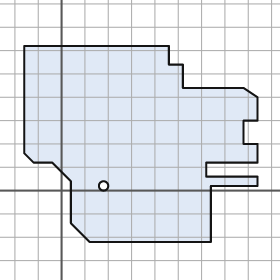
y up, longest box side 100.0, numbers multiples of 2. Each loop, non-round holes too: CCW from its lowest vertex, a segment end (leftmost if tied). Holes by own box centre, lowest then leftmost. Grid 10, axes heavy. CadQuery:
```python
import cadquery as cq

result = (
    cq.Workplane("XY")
    .moveTo(12.0, -22.0)
    .lineTo(64.0, -22.0)
    .lineTo(64.0, 2.0)
    .lineTo(84.0, 2.0)
    .lineTo(84.0, 6.0)
    .lineTo(62.0, 6.0)
    .lineTo(62.0, 12.0)
    .lineTo(84.0, 12.0)
    .lineTo(84.0, 20.0)
    .lineTo(78.0, 20.0)
    .lineTo(78.0, 30.0)
    .lineTo(84.0, 30.0)
    .lineTo(84.0, 40.0)
    .lineTo(78.0, 44.0)
    .lineTo(52.0, 44.0)
    .lineTo(52.0, 54.0)
    .lineTo(46.0, 54.0)
    .lineTo(46.0, 62.0)
    .lineTo(-16.0, 62.0)
    .lineTo(-16.0, 16.0)
    .lineTo(-12.0, 12.0)
    .lineTo(-4.0, 12.0)
    .lineTo(4.0, 4.0)
    .lineTo(4.0, -14.0)
    .close()
    .moveTo(18.0, 2.0)
    .circle(2.0)
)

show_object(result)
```